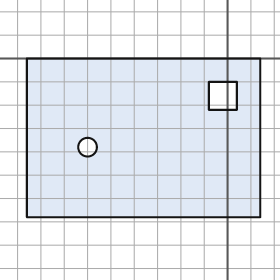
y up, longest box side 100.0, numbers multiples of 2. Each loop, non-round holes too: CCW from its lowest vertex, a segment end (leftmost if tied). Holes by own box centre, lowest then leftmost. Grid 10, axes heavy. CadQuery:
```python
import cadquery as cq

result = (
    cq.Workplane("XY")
    .moveTo(-86.0, -68.0)
    .lineTo(14.0, -68.0)
    .lineTo(14.0, 0.0)
    .lineTo(-86.0, 0.0)
    .close()
    .moveTo(-60.0, -38.0)
    .circle(4.0)
    .moveTo(-8.0, -22.0)
    .lineTo(4.0, -22.0)
    .lineTo(4.0, -10.0)
    .lineTo(-8.0, -10.0)
    .close()
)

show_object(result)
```